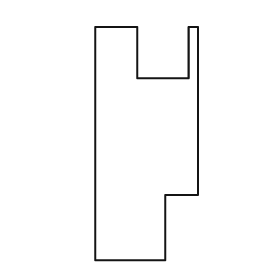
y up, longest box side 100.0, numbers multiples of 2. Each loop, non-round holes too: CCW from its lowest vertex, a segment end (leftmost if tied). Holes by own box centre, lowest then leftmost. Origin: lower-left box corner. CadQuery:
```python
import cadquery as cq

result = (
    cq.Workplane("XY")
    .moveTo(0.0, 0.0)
    .lineTo(30.0, 0.0)
    .lineTo(30.0, 28.0)
    .lineTo(44.0, 28.0)
    .lineTo(44.0, 100.0)
    .lineTo(40.0, 100.0)
    .lineTo(40.0, 78.0)
    .lineTo(18.0, 78.0)
    .lineTo(18.0, 100.0)
    .lineTo(0.0, 100.0)
    .close()
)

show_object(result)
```